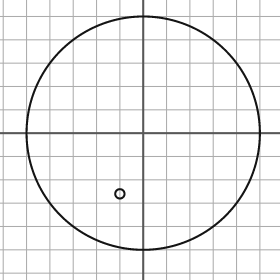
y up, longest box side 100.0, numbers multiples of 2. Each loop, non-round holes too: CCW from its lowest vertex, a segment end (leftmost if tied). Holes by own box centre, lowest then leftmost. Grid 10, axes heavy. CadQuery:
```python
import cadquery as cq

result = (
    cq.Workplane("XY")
    .moveTo(0.0, 0.0)
    .circle(50.0)
    .moveTo(-10.0, -26.0)
    .circle(2.0)
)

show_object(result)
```